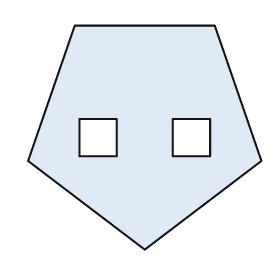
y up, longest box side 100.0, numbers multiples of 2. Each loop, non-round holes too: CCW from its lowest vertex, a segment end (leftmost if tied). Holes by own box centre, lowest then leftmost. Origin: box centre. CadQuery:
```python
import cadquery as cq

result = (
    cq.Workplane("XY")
    .moveTo(0.0, -48.0)
    .lineTo(50.0, -10.0)
    .lineTo(30.0, 48.0)
    .lineTo(-30.0, 48.0)
    .lineTo(-50.0, -10.0)
    .close()
    .moveTo(-28.0, -8.0)
    .lineTo(-12.0, -8.0)
    .lineTo(-12.0, 8.0)
    .lineTo(-28.0, 8.0)
    .close()
    .moveTo(12.0, -8.0)
    .lineTo(28.0, -8.0)
    .lineTo(28.0, 8.0)
    .lineTo(12.0, 8.0)
    .close()
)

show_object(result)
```